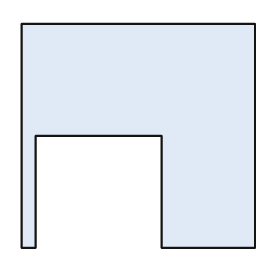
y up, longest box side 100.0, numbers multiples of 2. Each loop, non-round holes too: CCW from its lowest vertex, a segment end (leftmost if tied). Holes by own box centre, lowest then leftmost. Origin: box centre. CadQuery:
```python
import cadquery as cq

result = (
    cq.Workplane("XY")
    .moveTo(-50.0, -48.0)
    .lineTo(-44.0, -48.0)
    .lineTo(-44.0, 0.0)
    .lineTo(10.0, 0.0)
    .lineTo(10.0, -48.0)
    .lineTo(50.0, -48.0)
    .lineTo(50.0, 48.0)
    .lineTo(-50.0, 48.0)
    .close()
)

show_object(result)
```